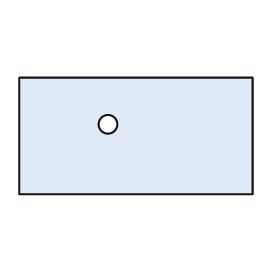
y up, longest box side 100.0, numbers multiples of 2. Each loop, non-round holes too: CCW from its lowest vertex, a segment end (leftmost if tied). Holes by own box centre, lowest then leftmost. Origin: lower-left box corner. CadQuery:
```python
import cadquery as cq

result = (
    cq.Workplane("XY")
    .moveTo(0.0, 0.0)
    .lineTo(100.0, 0.0)
    .lineTo(100.0, 50.0)
    .lineTo(0.0, 50.0)
    .close()
    .moveTo(38.0, 30.0)
    .circle(4.0)
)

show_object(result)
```